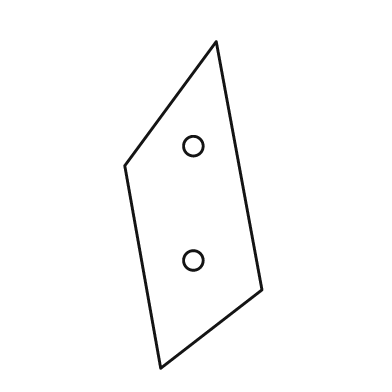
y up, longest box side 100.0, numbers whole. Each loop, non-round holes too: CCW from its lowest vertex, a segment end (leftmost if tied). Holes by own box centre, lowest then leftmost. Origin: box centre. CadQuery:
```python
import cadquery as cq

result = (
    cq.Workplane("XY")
    .moveTo(-10.0, -50.0)
    .lineTo(21.0, -26.0)
    .lineTo(7.0, 50.0)
    .lineTo(-21.0, 12.0)
    .close()
    .moveTo(0.0, -17.0)
    .circle(3.0)
    .moveTo(0.0, 18.0)
    .circle(3.0)
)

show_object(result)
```